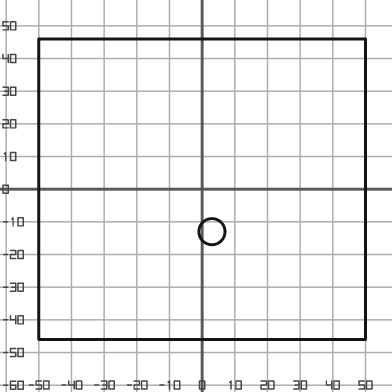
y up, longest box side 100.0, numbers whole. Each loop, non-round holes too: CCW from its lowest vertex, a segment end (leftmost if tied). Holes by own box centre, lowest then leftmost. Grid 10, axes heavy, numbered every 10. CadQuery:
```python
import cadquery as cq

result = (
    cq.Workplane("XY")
    .moveTo(-50.0, -46.0)
    .lineTo(50.0, -46.0)
    .lineTo(50.0, 46.0)
    .lineTo(-50.0, 46.0)
    .close()
    .moveTo(3.0, -13.0)
    .circle(4.0)
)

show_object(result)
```